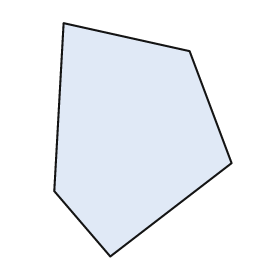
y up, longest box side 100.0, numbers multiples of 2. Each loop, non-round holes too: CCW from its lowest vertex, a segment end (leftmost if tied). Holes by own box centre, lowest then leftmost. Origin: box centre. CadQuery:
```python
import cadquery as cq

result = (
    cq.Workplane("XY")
    .moveTo(-14.0, -50.0)
    .lineTo(38.0, -10.0)
    .lineTo(20.0, 38.0)
    .lineTo(-34.0, 50.0)
    .lineTo(-38.0, -22.0)
    .close()
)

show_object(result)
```